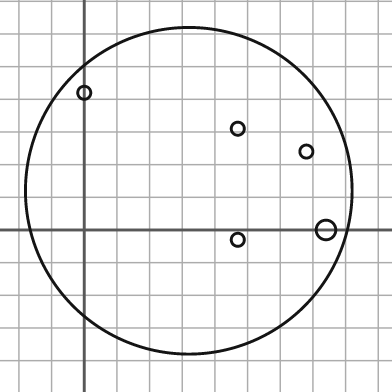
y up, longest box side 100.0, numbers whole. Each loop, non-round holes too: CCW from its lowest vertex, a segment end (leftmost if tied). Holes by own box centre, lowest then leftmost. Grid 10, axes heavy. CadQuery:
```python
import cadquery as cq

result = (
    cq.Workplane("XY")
    .moveTo(32.0, 12.0)
    .circle(50.0)
    .moveTo(47.0, -3.0)
    .circle(2.0)
    .moveTo(74.0, 0.0)
    .circle(3.0)
    .moveTo(68.0, 24.0)
    .circle(2.0)
    .moveTo(47.0, 31.0)
    .circle(2.0)
    .moveTo(0.0, 42.0)
    .circle(2.0)
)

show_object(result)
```